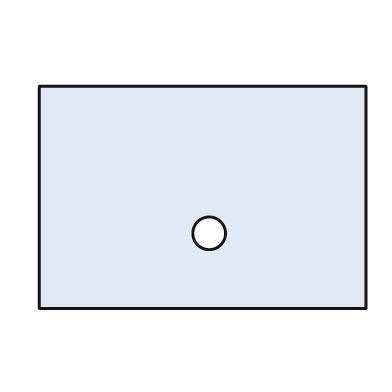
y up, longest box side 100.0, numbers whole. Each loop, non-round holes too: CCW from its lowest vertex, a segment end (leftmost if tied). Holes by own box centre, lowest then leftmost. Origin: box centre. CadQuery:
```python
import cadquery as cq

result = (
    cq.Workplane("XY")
    .moveTo(-50.0, -34.0)
    .lineTo(50.0, -34.0)
    .lineTo(50.0, 34.0)
    .lineTo(-50.0, 34.0)
    .close()
    .moveTo(2.0, -11.0)
    .circle(5.0)
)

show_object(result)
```